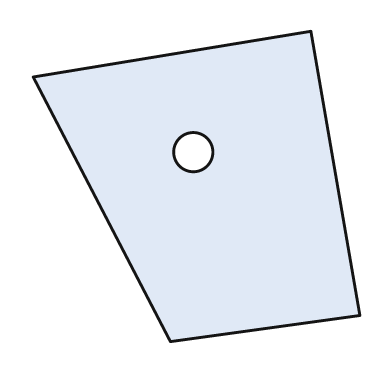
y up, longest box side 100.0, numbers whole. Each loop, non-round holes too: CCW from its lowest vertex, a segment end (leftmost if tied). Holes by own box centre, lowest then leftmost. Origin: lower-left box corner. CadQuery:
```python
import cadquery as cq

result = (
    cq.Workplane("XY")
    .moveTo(42.0, 0.0)
    .lineTo(100.0, 8.0)
    .lineTo(85.0, 95.0)
    .lineTo(0.0, 81.0)
    .close()
    .moveTo(49.0, 58.0)
    .circle(6.0)
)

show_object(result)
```